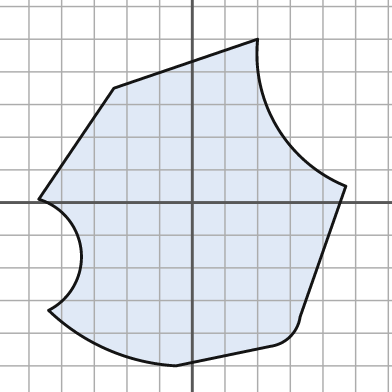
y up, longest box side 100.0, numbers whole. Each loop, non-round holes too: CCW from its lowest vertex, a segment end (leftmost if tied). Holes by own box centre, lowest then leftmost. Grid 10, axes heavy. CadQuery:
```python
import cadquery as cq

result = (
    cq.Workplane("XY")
    .moveTo(-5.0, -50.0)
    .lineTo(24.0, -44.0)
    .threePointArc((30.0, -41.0), (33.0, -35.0))
    .lineTo(47.0, 5.0)
    .threePointArc((26.0, 23.0), (20.0, 50.0))
    .lineTo(-24.0, 35.0)
    .lineTo(-47.0, 1.0)
    .threePointArc((-34.0, -15.0), (-44.0, -33.0))
    .threePointArc((-26.0, -45.0), (-5.0, -50.0))
    .close()
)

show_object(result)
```